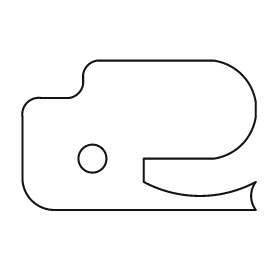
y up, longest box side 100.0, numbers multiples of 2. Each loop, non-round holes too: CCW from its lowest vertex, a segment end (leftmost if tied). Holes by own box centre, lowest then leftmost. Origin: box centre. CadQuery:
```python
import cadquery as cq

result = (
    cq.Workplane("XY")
    .moveTo(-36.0, -32.0)
    .lineTo(50.0, -32.0)
    .threePointArc((48.0, -26.0), (50.0, -20.0))
    .threePointArc((26.0, -26.0), (2.0, -20.0))
    .lineTo(2.0, -10.0)
    .lineTo(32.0, -10.0)
    .threePointArc((44.0, -4.0), (50.0, 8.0))
    .lineTo(50.0, 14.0)
    .threePointArc((44.0, 26.0), (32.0, 32.0))
    .lineTo(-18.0, 32.0)
    .threePointArc((-22.0, 30.0), (-24.0, 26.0))
    .lineTo(-24.0, 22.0)
    .threePointArc((-26.0, 18.0), (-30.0, 16.0))
    .lineTo(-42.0, 16.0)
    .threePointArc((-48.0, 14.0), (-50.0, 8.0))
    .lineTo(-50.0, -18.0)
    .threePointArc((-46.0, -28.0), (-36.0, -32.0))
    .close()
    .moveTo(-20.0, -10.0)
    .circle(6.0)
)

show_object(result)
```